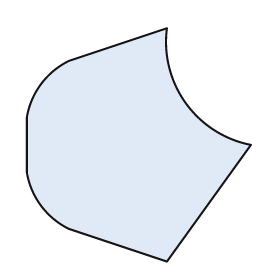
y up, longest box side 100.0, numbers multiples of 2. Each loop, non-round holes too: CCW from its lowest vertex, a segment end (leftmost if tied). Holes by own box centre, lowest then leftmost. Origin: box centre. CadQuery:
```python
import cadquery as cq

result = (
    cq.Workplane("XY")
    .moveTo(12.0, -50.0)
    .lineTo(48.0, 0.0)
    .threePointArc((20.0, 18.0), (12.0, 50.0))
    .lineTo(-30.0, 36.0)
    .threePointArc((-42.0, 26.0), (-48.0, 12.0))
    .lineTo(-48.0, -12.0)
    .threePointArc((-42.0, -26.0), (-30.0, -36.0))
    .close()
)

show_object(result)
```